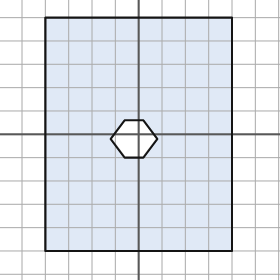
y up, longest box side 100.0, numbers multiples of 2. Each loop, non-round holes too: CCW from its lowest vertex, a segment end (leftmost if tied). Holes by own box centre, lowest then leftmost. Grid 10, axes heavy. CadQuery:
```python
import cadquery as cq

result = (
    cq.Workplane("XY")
    .moveTo(-40.0, -50.0)
    .lineTo(40.0, -50.0)
    .lineTo(40.0, 50.0)
    .lineTo(-40.0, 50.0)
    .close()
    .moveTo(-6.0, -10.0)
    .lineTo(2.0, -10.0)
    .lineTo(8.0, -2.0)
    .lineTo(2.0, 6.0)
    .lineTo(-6.0, 6.0)
    .lineTo(-12.0, -2.0)
    .close()
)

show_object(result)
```